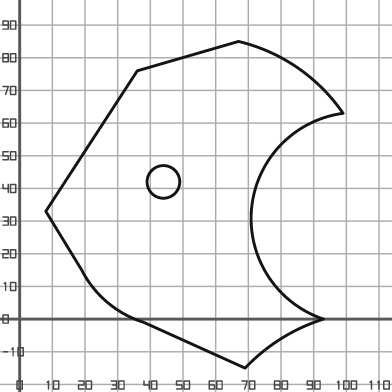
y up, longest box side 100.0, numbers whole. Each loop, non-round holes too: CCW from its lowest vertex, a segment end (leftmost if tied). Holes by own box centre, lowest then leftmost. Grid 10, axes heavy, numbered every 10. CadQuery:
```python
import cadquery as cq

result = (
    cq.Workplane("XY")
    .moveTo(69.0, -15.0)
    .threePointArc((80.0, -6.0), (93.0, 0.0))
    .threePointArc((71.0, 34.0), (99.0, 63.0))
    .threePointArc((85.0, 77.0), (67.0, 85.0))
    .lineTo(36.0, 76.0)
    .lineTo(8.0, 33.0)
    .lineTo(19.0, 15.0)
    .threePointArc((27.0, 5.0), (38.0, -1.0))
    .close()
    .moveTo(44.0, 42.0)
    .circle(5.0)
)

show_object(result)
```